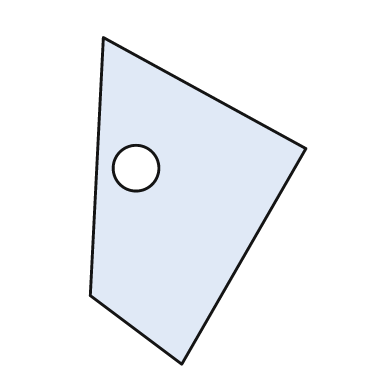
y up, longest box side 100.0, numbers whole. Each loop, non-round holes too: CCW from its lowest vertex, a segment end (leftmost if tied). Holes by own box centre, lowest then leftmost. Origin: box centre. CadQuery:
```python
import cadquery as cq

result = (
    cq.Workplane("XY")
    .moveTo(-5.0, -50.0)
    .lineTo(33.0, 16.0)
    .lineTo(-29.0, 50.0)
    .lineTo(-33.0, -29.0)
    .close()
    .moveTo(-19.0, 10.0)
    .circle(7.0)
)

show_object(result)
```